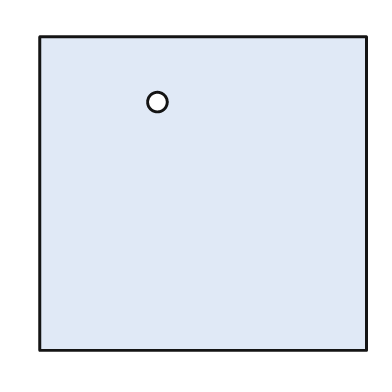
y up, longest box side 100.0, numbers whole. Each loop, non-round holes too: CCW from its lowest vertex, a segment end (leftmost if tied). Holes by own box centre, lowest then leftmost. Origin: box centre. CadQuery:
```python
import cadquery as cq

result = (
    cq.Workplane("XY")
    .moveTo(-50.0, -48.0)
    .lineTo(50.0, -48.0)
    .lineTo(50.0, 48.0)
    .lineTo(-50.0, 48.0)
    .close()
    .moveTo(-14.0, 28.0)
    .circle(3.0)
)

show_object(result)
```